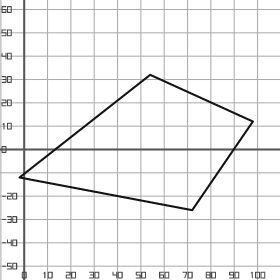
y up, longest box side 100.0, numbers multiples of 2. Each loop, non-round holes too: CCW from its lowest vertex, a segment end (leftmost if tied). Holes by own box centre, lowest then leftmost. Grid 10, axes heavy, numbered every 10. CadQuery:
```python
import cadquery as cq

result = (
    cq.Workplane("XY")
    .moveTo(72.0, -26.0)
    .lineTo(98.0, 12.0)
    .lineTo(54.0, 32.0)
    .lineTo(-2.0, -12.0)
    .close()
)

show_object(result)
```